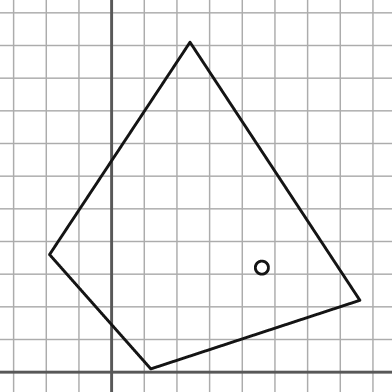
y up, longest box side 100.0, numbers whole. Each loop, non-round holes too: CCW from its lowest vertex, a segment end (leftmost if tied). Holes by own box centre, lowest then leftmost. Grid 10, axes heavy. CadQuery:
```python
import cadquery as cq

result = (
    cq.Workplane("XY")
    .moveTo(12.0, 1.0)
    .lineTo(76.0, 22.0)
    .lineTo(24.0, 101.0)
    .lineTo(-19.0, 36.0)
    .close()
    .moveTo(46.0, 32.0)
    .circle(2.0)
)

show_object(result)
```